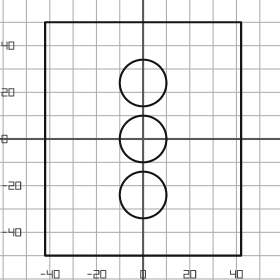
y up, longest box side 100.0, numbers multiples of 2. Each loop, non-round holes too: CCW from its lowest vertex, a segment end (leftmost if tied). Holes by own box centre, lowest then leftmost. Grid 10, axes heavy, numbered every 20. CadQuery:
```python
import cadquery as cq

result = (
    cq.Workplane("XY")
    .moveTo(-42.0, -50.0)
    .lineTo(42.0, -50.0)
    .lineTo(42.0, 50.0)
    .lineTo(-42.0, 50.0)
    .close()
    .moveTo(0.0, -24.0)
    .circle(10.0)
    .moveTo(0.0, 0.0)
    .circle(10.0)
    .moveTo(0.0, 24.0)
    .circle(10.0)
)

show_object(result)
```